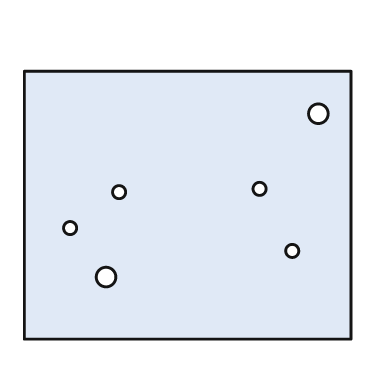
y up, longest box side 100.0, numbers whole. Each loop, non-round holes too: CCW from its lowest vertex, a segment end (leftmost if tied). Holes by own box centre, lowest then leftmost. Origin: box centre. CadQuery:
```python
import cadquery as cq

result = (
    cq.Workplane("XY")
    .moveTo(-50.0, -41.0)
    .lineTo(50.0, -41.0)
    .lineTo(50.0, 41.0)
    .lineTo(-50.0, 41.0)
    .close()
    .moveTo(-25.0, -22.0)
    .circle(3.0)
    .moveTo(32.0, -14.0)
    .circle(2.0)
    .moveTo(-36.0, -7.0)
    .circle(2.0)
    .moveTo(-21.0, 4.0)
    .circle(2.0)
    .moveTo(22.0, 5.0)
    .circle(2.0)
    .moveTo(40.0, 28.0)
    .circle(3.0)
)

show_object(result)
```